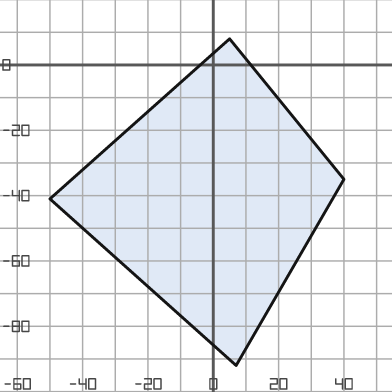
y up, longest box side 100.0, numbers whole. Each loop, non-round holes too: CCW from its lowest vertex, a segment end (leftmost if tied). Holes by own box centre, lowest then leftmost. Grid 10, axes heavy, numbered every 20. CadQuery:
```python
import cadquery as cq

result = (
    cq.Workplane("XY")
    .moveTo(7.0, -92.0)
    .lineTo(40.0, -35.0)
    .lineTo(5.0, 8.0)
    .lineTo(-50.0, -41.0)
    .close()
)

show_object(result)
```